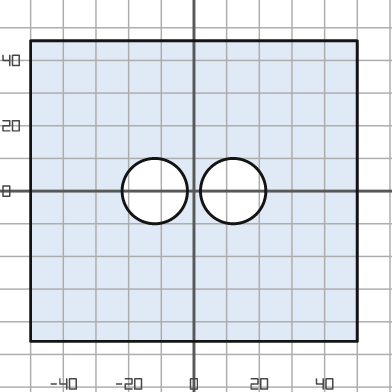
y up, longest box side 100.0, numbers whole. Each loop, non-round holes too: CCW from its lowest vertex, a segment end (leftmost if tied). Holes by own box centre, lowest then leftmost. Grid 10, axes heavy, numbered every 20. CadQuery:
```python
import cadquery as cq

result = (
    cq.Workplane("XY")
    .moveTo(-50.0, -46.0)
    .lineTo(50.0, -46.0)
    .lineTo(50.0, 46.0)
    .lineTo(-50.0, 46.0)
    .close()
    .moveTo(-12.0, 0.0)
    .circle(10.0)
    .moveTo(12.0, 0.0)
    .circle(10.0)
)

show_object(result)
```